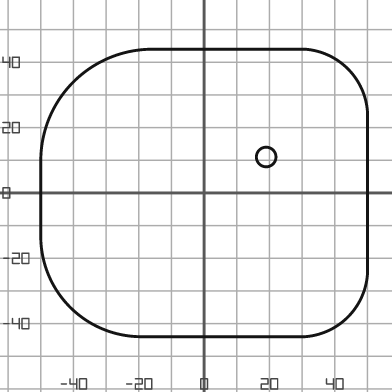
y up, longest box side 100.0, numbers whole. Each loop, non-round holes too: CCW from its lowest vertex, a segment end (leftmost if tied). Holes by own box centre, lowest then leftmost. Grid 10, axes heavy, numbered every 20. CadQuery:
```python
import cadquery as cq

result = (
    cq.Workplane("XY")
    .moveTo(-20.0, -44.0)
    .lineTo(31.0, -44.0)
    .threePointArc((44.0, -38.0), (50.0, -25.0))
    .lineTo(50.0, 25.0)
    .threePointArc((44.0, 38.0), (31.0, 44.0))
    .lineTo(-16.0, 44.0)
    .threePointArc((-40.0, 34.0), (-50.0, 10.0))
    .lineTo(-50.0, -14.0)
    .threePointArc((-41.0, -35.0), (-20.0, -44.0))
    .close()
    .moveTo(19.0, 11.0)
    .circle(3.0)
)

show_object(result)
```